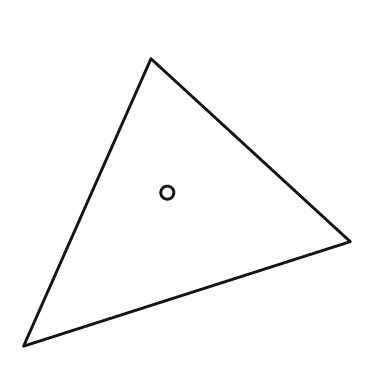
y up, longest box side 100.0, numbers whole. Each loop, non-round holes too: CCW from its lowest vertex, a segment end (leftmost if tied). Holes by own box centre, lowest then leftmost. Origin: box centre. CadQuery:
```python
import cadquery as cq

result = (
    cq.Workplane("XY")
    .moveTo(-50.0, -44.0)
    .lineTo(50.0, -12.0)
    .lineTo(-11.0, 44.0)
    .close()
    .moveTo(-6.0, 3.0)
    .circle(2.0)
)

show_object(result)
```